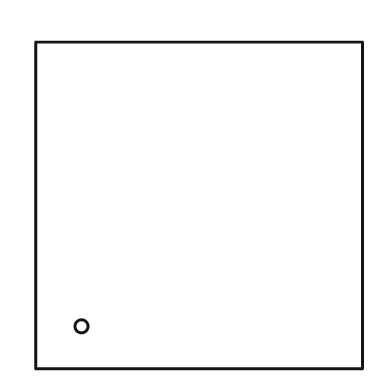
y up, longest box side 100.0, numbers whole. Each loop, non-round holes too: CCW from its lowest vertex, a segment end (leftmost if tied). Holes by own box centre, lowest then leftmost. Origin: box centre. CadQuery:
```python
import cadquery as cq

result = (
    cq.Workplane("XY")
    .moveTo(-50.0, -50.0)
    .lineTo(50.0, -50.0)
    .lineTo(50.0, 50.0)
    .lineTo(-50.0, 50.0)
    .close()
    .moveTo(-36.0, -37.0)
    .circle(2.0)
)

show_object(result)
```